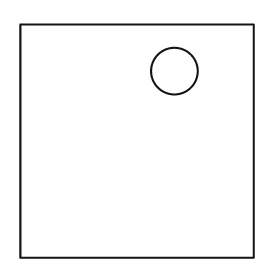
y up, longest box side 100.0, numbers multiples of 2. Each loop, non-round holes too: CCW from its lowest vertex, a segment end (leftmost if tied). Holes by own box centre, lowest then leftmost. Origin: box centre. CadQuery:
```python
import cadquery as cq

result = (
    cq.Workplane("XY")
    .moveTo(-50.0, -50.0)
    .lineTo(50.0, -50.0)
    .lineTo(50.0, 50.0)
    .lineTo(-50.0, 50.0)
    .close()
    .moveTo(16.0, 30.0)
    .circle(10.0)
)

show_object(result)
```